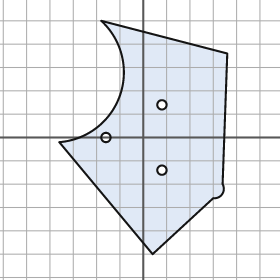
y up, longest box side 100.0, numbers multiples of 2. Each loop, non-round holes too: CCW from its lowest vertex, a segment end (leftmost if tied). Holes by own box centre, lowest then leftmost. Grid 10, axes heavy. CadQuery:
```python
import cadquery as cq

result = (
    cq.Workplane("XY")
    .moveTo(4.0, -50.0)
    .lineTo(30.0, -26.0)
    .threePointArc((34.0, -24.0), (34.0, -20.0))
    .lineTo(36.0, 36.0)
    .lineTo(-18.0, 50.0)
    .threePointArc((-10.0, 18.0), (-36.0, -2.0))
    .close()
    .moveTo(8.0, -14.0)
    .circle(2.0)
    .moveTo(-16.0, 0.0)
    .circle(2.0)
    .moveTo(8.0, 14.0)
    .circle(2.0)
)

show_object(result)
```